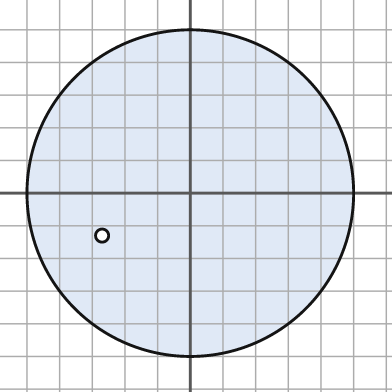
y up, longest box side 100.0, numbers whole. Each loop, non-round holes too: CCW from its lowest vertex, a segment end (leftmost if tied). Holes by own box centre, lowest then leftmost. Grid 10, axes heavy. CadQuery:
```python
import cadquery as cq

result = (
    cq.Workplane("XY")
    .moveTo(0.0, 0.0)
    .circle(50.0)
    .moveTo(-27.0, -13.0)
    .circle(2.0)
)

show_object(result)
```